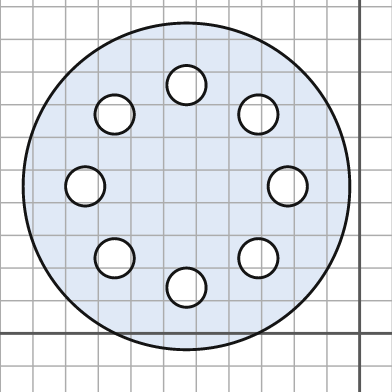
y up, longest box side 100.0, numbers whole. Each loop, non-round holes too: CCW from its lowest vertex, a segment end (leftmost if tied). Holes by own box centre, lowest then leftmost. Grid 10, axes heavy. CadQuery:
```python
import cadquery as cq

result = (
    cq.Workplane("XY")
    .moveTo(-53.0, 45.0)
    .circle(50.0)
    .moveTo(-53.0, 14.0)
    .circle(6.0)
    .moveTo(-75.0, 23.0)
    .circle(6.0)
    .moveTo(-31.0, 23.0)
    .circle(6.0)
    .moveTo(-84.0, 45.0)
    .circle(6.0)
    .moveTo(-22.0, 45.0)
    .circle(6.0)
    .moveTo(-75.0, 67.0)
    .circle(6.0)
    .moveTo(-31.0, 67.0)
    .circle(6.0)
    .moveTo(-53.0, 76.0)
    .circle(6.0)
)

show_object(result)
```